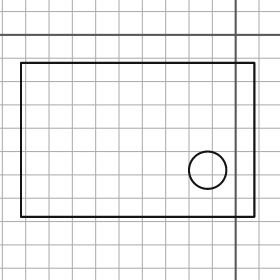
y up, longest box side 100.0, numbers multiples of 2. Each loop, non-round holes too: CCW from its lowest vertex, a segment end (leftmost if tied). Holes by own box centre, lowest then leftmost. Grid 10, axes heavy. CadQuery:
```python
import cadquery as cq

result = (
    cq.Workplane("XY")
    .moveTo(-92.0, -78.0)
    .lineTo(8.0, -78.0)
    .lineTo(8.0, -12.0)
    .lineTo(-92.0, -12.0)
    .close()
    .moveTo(-12.0, -58.0)
    .circle(8.0)
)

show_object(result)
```